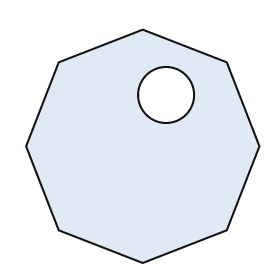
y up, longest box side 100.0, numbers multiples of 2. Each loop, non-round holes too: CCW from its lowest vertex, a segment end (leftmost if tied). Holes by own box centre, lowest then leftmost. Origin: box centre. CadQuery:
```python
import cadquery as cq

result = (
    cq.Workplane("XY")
    .moveTo(0.0, -50.0)
    .lineTo(36.0, -36.0)
    .lineTo(50.0, 0.0)
    .lineTo(36.0, 36.0)
    .lineTo(0.0, 50.0)
    .lineTo(-36.0, 36.0)
    .lineTo(-50.0, 0.0)
    .lineTo(-36.0, -36.0)
    .close()
    .moveTo(10.0, 22.0)
    .circle(12.0)
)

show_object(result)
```